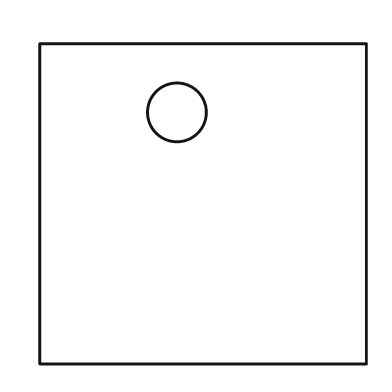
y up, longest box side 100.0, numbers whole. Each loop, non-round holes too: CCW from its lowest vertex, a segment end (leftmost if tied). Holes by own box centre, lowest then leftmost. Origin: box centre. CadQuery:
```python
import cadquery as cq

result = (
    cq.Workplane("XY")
    .moveTo(-50.0, -49.0)
    .lineTo(50.0, -49.0)
    .lineTo(50.0, 49.0)
    .lineTo(-50.0, 49.0)
    .close()
    .moveTo(-8.0, 28.0)
    .circle(9.0)
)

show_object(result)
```